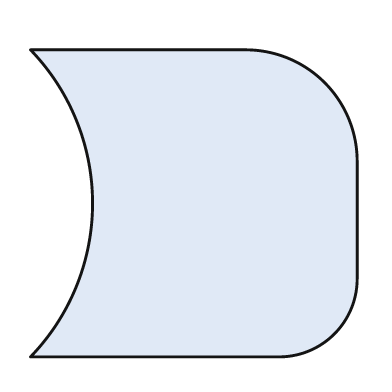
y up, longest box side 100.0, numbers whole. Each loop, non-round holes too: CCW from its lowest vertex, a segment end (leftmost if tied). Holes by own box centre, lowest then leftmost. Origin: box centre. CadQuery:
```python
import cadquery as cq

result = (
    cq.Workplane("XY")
    .moveTo(-50.0, -47.0)
    .lineTo(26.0, -47.0)
    .threePointArc((43.0, -40.0), (50.0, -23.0))
    .lineTo(50.0, 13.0)
    .threePointArc((40.0, 37.0), (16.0, 47.0))
    .lineTo(-50.0, 47.0)
    .threePointArc((-31.0, 0.0), (-50.0, -47.0))
    .close()
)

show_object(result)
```